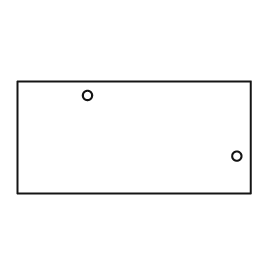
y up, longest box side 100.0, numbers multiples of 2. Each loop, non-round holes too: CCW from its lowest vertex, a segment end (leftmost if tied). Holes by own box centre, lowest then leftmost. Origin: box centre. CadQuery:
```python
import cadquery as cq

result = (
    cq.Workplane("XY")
    .moveTo(-50.0, -24.0)
    .lineTo(50.0, -24.0)
    .lineTo(50.0, 24.0)
    .lineTo(-50.0, 24.0)
    .close()
    .moveTo(44.0, -8.0)
    .circle(2.0)
    .moveTo(-20.0, 18.0)
    .circle(2.0)
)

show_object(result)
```